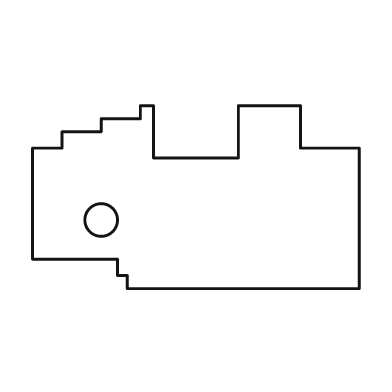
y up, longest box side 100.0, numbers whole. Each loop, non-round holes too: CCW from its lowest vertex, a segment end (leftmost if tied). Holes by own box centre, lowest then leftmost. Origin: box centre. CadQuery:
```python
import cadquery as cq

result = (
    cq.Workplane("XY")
    .moveTo(-21.0, -28.0)
    .lineTo(50.0, -28.0)
    .lineTo(50.0, 15.0)
    .lineTo(32.0, 15.0)
    .lineTo(32.0, 28.0)
    .lineTo(13.0, 28.0)
    .lineTo(13.0, 12.0)
    .lineTo(-13.0, 12.0)
    .lineTo(-13.0, 28.0)
    .lineTo(-17.0, 28.0)
    .lineTo(-17.0, 24.0)
    .lineTo(-29.0, 24.0)
    .lineTo(-29.0, 20.0)
    .lineTo(-41.0, 20.0)
    .lineTo(-41.0, 15.0)
    .lineTo(-50.0, 15.0)
    .lineTo(-50.0, -19.0)
    .lineTo(-24.0, -19.0)
    .lineTo(-24.0, -24.0)
    .lineTo(-21.0, -24.0)
    .close()
    .moveTo(-29.0, -7.0)
    .circle(5.0)
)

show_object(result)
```